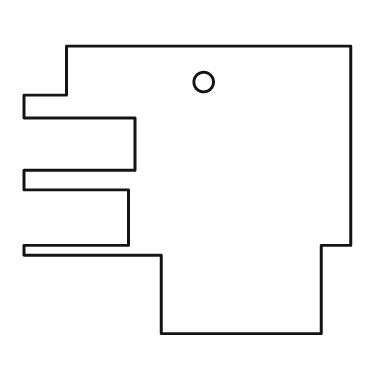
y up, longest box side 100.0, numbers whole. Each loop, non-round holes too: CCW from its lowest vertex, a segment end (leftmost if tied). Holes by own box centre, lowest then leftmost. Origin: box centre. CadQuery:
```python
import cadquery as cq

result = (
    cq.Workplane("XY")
    .moveTo(-8.0, -44.0)
    .lineTo(41.0, -44.0)
    .lineTo(41.0, -17.0)
    .lineTo(50.0, -17.0)
    .lineTo(50.0, 44.0)
    .lineTo(-37.0, 44.0)
    .lineTo(-37.0, 29.0)
    .lineTo(-50.0, 29.0)
    .lineTo(-50.0, 22.0)
    .lineTo(-16.0, 22.0)
    .lineTo(-16.0, 6.0)
    .lineTo(-50.0, 6.0)
    .lineTo(-50.0, 0.0)
    .lineTo(-18.0, 0.0)
    .lineTo(-18.0, -17.0)
    .lineTo(-50.0, -17.0)
    .lineTo(-50.0, -20.0)
    .lineTo(-8.0, -20.0)
    .close()
    .moveTo(5.0, 33.0)
    .circle(3.0)
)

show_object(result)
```